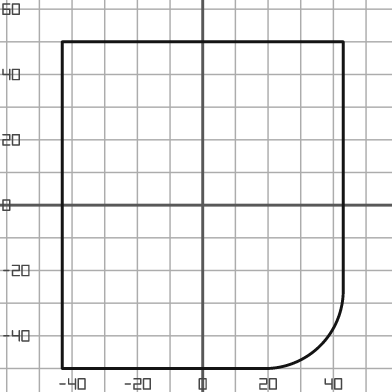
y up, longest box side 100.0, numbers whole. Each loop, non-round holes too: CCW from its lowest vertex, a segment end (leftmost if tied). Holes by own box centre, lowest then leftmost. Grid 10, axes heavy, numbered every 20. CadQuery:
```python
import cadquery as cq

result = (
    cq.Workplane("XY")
    .moveTo(-43.0, -50.0)
    .lineTo(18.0, -50.0)
    .threePointArc((36.0, -43.0), (43.0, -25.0))
    .lineTo(43.0, 50.0)
    .lineTo(-43.0, 50.0)
    .close()
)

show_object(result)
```